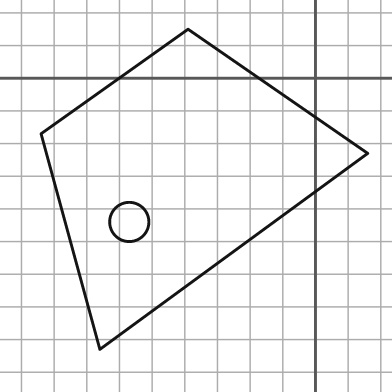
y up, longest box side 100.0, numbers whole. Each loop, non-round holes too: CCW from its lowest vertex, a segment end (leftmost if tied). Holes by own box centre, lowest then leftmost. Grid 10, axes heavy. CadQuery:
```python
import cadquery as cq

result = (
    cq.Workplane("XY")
    .moveTo(-66.0, -83.0)
    .lineTo(16.0, -23.0)
    .lineTo(-39.0, 15.0)
    .lineTo(-84.0, -17.0)
    .close()
    .moveTo(-57.0, -44.0)
    .circle(6.0)
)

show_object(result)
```